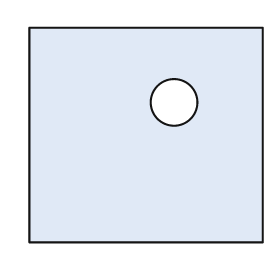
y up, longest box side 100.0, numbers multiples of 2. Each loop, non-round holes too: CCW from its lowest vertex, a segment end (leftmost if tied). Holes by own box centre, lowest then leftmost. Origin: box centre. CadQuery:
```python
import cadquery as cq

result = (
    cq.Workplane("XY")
    .moveTo(-50.0, -46.0)
    .lineTo(50.0, -46.0)
    .lineTo(50.0, 46.0)
    .lineTo(-50.0, 46.0)
    .close()
    .moveTo(12.0, 14.0)
    .circle(10.0)
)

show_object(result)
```